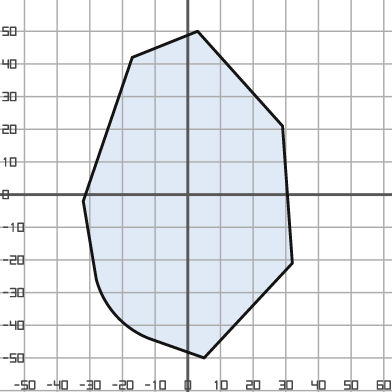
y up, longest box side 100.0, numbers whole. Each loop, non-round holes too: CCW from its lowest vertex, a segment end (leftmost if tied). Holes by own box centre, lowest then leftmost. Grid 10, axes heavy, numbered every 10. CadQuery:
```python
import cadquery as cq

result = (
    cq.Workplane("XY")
    .moveTo(5.0, -50.0)
    .lineTo(32.0, -21.0)
    .lineTo(29.0, 21.0)
    .lineTo(3.0, 50.0)
    .lineTo(-17.0, 42.0)
    .lineTo(-32.0, -2.0)
    .lineTo(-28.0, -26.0)
    .threePointArc((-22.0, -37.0), (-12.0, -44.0))
    .close()
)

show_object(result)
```